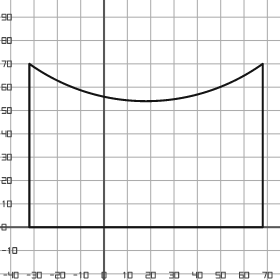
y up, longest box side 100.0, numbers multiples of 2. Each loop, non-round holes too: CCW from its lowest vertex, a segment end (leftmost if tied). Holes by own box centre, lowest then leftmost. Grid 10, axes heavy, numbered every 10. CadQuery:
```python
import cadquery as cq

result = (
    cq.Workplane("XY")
    .moveTo(-32.0, 0.0)
    .lineTo(68.0, 0.0)
    .lineTo(68.0, 70.0)
    .threePointArc((18.0, 54.0), (-32.0, 70.0))
    .close()
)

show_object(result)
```